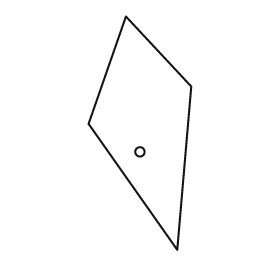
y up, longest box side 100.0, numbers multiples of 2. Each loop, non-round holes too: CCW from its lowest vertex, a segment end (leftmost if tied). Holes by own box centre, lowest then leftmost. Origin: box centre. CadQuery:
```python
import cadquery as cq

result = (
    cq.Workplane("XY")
    .moveTo(16.0, -50.0)
    .lineTo(22.0, 20.0)
    .lineTo(-6.0, 50.0)
    .lineTo(-22.0, 4.0)
    .close()
    .moveTo(0.0, -8.0)
    .circle(2.0)
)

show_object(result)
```